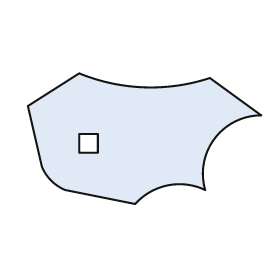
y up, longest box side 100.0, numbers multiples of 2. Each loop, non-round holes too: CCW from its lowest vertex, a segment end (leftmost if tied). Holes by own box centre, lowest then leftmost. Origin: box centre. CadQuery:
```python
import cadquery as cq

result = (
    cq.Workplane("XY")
    .moveTo(-4.0, -28.0)
    .threePointArc((10.0, -20.0), (26.0, -22.0))
    .threePointArc((30.0, 0.0), (50.0, 10.0))
    .lineTo(28.0, 26.0)
    .threePointArc((0.0, 22.0), (-28.0, 28.0))
    .lineTo(-50.0, 14.0)
    .lineTo(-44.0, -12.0)
    .threePointArc((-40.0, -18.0), (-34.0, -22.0))
    .close()
    .moveTo(-28.0, -6.0)
    .lineTo(-20.0, -6.0)
    .lineTo(-20.0, 2.0)
    .lineTo(-28.0, 2.0)
    .close()
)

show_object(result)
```